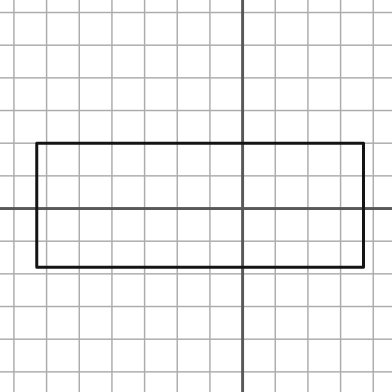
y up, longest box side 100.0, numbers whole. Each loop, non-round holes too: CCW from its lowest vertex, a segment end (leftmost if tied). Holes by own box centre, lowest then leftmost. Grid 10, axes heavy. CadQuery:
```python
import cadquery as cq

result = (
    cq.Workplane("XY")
    .moveTo(-63.0, -18.0)
    .lineTo(37.0, -18.0)
    .lineTo(37.0, 20.0)
    .lineTo(-63.0, 20.0)
    .close()
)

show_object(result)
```